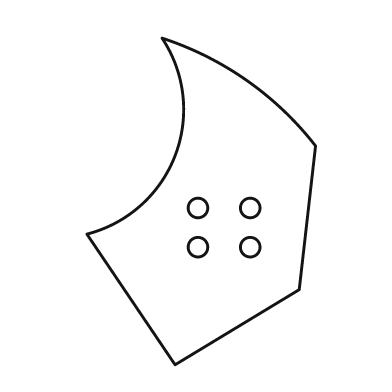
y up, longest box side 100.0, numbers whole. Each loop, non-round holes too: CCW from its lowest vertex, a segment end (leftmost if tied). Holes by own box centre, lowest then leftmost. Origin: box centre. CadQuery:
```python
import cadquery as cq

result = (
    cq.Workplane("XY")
    .moveTo(-8.0, -50.0)
    .lineTo(30.0, -27.0)
    .lineTo(35.0, 17.0)
    .threePointArc((14.0, 37.0), (-12.0, 50.0))
    .threePointArc((-8.0, 14.0), (-35.0, -10.0))
    .close()
    .moveTo(-1.0, -14.0)
    .circle(3.0)
    .moveTo(15.0, -14.0)
    .circle(3.0)
    .moveTo(-1.0, -2.0)
    .circle(3.0)
    .moveTo(15.0, -2.0)
    .circle(3.0)
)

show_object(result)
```